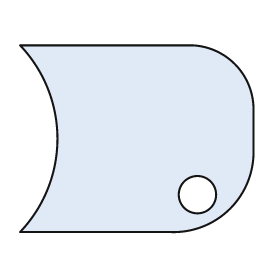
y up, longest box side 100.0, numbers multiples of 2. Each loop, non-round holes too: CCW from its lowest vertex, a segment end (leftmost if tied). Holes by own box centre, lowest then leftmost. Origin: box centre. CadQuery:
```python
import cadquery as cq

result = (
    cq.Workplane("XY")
    .moveTo(-50.0, -40.0)
    .lineTo(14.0, -40.0)
    .threePointArc((40.0, -30.0), (50.0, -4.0))
    .lineTo(50.0, 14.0)
    .threePointArc((42.0, 32.0), (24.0, 40.0))
    .lineTo(-50.0, 40.0)
    .threePointArc((-34.0, 0.0), (-50.0, -40.0))
    .close()
    .moveTo(26.0, -24.0)
    .circle(8.0)
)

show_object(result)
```